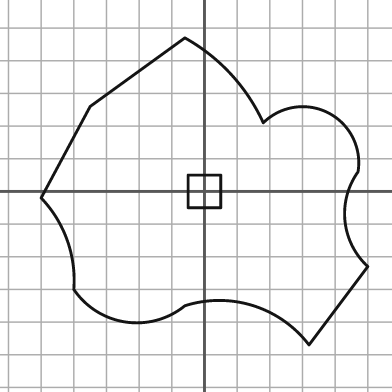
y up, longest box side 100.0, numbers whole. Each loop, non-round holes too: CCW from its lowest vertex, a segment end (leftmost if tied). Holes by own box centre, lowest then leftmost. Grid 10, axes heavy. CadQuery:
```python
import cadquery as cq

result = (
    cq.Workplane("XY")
    .moveTo(32.0, -47.0)
    .lineTo(50.0, -23.0)
    .threePointArc((43.0, -9.0), (47.0, 6.0))
    .threePointArc((38.0, 24.0), (18.0, 21.0))
    .threePointArc((8.0, 36.0), (-6.0, 47.0))
    .lineTo(-35.0, 26.0)
    .lineTo(-50.0, -2.0)
    .threePointArc((-42.0, -15.0), (-40.0, -30.0))
    .threePointArc((-24.0, -40.0), (-6.0, -35.0))
    .threePointArc((15.0, -35.0), (32.0, -47.0))
    .close()
    .moveTo(-5.0, -5.0)
    .lineTo(5.0, -5.0)
    .lineTo(5.0, 5.0)
    .lineTo(-5.0, 5.0)
    .close()
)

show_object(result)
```